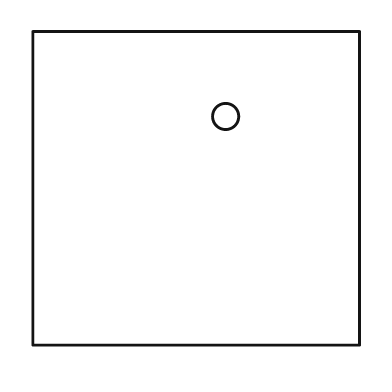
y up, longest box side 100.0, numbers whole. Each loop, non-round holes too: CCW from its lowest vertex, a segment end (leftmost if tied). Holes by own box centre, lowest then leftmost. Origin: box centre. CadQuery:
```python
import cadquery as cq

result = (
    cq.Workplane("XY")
    .moveTo(-50.0, -48.0)
    .lineTo(50.0, -48.0)
    .lineTo(50.0, 48.0)
    .lineTo(-50.0, 48.0)
    .close()
    .moveTo(9.0, 22.0)
    .circle(4.0)
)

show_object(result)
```